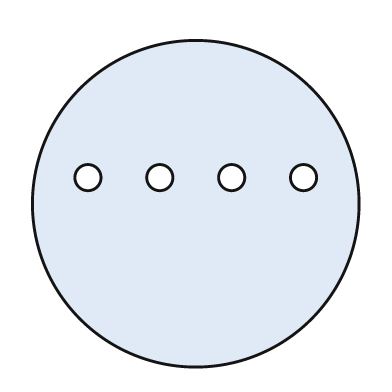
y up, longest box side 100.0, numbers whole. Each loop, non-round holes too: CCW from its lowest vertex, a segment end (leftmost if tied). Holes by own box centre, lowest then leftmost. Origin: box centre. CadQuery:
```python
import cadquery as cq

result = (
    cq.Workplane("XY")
    .moveTo(0.0, 0.0)
    .circle(50.0)
    .moveTo(-33.0, 8.0)
    .circle(4.0)
    .moveTo(-11.0, 8.0)
    .circle(4.0)
    .moveTo(11.0, 8.0)
    .circle(4.0)
    .moveTo(33.0, 8.0)
    .circle(4.0)
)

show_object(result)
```